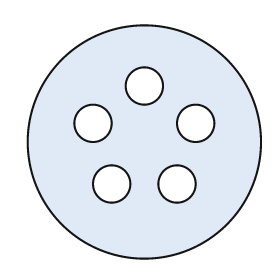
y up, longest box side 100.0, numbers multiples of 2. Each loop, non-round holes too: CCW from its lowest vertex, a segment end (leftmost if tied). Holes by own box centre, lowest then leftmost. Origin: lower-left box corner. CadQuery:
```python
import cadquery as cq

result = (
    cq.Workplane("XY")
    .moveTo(50.0, 50.0)
    .circle(50.0)
    .moveTo(36.0, 32.0)
    .circle(8.0)
    .moveTo(64.0, 32.0)
    .circle(8.0)
    .moveTo(28.0, 58.0)
    .circle(8.0)
    .moveTo(72.0, 58.0)
    .circle(8.0)
    .moveTo(50.0, 74.0)
    .circle(8.0)
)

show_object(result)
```